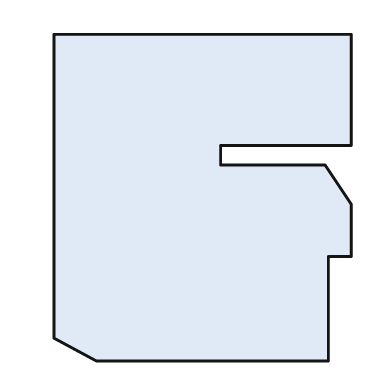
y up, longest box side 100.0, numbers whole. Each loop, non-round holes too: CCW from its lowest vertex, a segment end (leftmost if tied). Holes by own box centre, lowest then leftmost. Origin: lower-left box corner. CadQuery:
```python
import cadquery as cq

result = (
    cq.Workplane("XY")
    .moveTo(13.0, 0.0)
    .lineTo(84.0, 0.0)
    .lineTo(84.0, 32.0)
    .lineTo(91.0, 32.0)
    .lineTo(91.0, 48.0)
    .lineTo(83.0, 60.0)
    .lineTo(51.0, 60.0)
    .lineTo(51.0, 66.0)
    .lineTo(91.0, 66.0)
    .lineTo(91.0, 100.0)
    .lineTo(0.0, 100.0)
    .lineTo(0.0, 7.0)
    .close()
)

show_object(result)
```